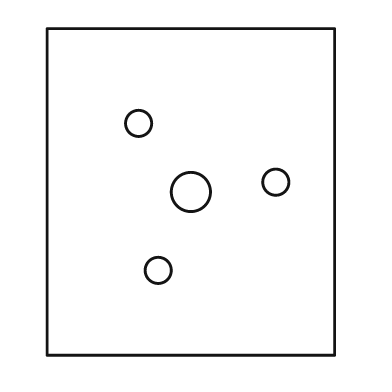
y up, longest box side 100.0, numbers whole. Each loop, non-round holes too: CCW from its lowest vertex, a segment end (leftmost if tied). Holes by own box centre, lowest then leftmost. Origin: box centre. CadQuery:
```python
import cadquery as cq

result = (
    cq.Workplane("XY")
    .moveTo(-44.0, -50.0)
    .lineTo(44.0, -50.0)
    .lineTo(44.0, 50.0)
    .lineTo(-44.0, 50.0)
    .close()
    .moveTo(-10.0, -24.0)
    .circle(4.0)
    .moveTo(0.0, 0.0)
    .circle(6.0)
    .moveTo(26.0, 3.0)
    .circle(4.0)
    .moveTo(-16.0, 21.0)
    .circle(4.0)
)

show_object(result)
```